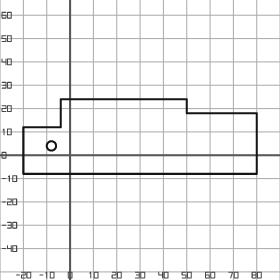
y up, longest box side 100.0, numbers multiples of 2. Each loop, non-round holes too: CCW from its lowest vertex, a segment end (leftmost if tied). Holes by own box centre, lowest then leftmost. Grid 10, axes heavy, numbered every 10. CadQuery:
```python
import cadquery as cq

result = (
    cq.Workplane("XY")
    .moveTo(-20.0, -8.0)
    .lineTo(80.0, -8.0)
    .lineTo(80.0, 18.0)
    .lineTo(50.0, 18.0)
    .lineTo(50.0, 24.0)
    .lineTo(-4.0, 24.0)
    .lineTo(-4.0, 12.0)
    .lineTo(-20.0, 12.0)
    .close()
    .moveTo(-8.0, 4.0)
    .circle(2.0)
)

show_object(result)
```